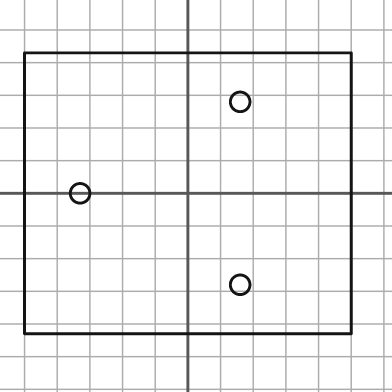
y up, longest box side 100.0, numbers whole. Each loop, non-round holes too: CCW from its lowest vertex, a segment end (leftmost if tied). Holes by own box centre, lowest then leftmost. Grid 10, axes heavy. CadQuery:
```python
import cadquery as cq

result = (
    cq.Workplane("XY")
    .moveTo(-50.0, -43.0)
    .lineTo(50.0, -43.0)
    .lineTo(50.0, 43.0)
    .lineTo(-50.0, 43.0)
    .close()
    .moveTo(16.0, -28.0)
    .circle(3.0)
    .moveTo(-33.0, 0.0)
    .circle(3.0)
    .moveTo(16.0, 28.0)
    .circle(3.0)
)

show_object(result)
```